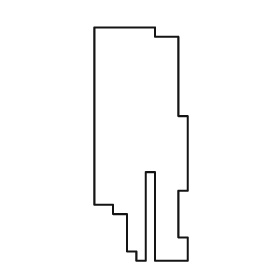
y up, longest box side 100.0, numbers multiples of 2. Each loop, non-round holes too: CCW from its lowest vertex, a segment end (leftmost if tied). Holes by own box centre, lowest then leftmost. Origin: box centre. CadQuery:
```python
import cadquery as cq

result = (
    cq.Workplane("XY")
    .moveTo(-2.0, -50.0)
    .lineTo(2.0, -50.0)
    .lineTo(2.0, -12.0)
    .lineTo(6.0, -12.0)
    .lineTo(6.0, -50.0)
    .lineTo(20.0, -50.0)
    .lineTo(20.0, -40.0)
    .lineTo(16.0, -40.0)
    .lineTo(16.0, -20.0)
    .lineTo(20.0, -20.0)
    .lineTo(20.0, 12.0)
    .lineTo(16.0, 12.0)
    .lineTo(16.0, 46.0)
    .lineTo(6.0, 46.0)
    .lineTo(6.0, 50.0)
    .lineTo(-20.0, 50.0)
    .lineTo(-20.0, -26.0)
    .lineTo(-12.0, -26.0)
    .lineTo(-12.0, -30.0)
    .lineTo(-6.0, -30.0)
    .lineTo(-6.0, -46.0)
    .lineTo(-2.0, -46.0)
    .close()
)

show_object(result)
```